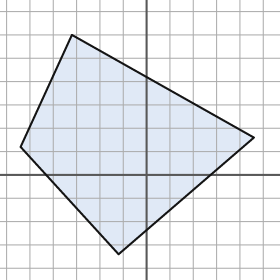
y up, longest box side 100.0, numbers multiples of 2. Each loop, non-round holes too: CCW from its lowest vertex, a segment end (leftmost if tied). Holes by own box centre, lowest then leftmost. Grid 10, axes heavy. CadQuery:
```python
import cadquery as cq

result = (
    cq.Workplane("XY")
    .moveTo(-12.0, -34.0)
    .lineTo(46.0, 16.0)
    .lineTo(-32.0, 60.0)
    .lineTo(-54.0, 12.0)
    .close()
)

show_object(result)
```